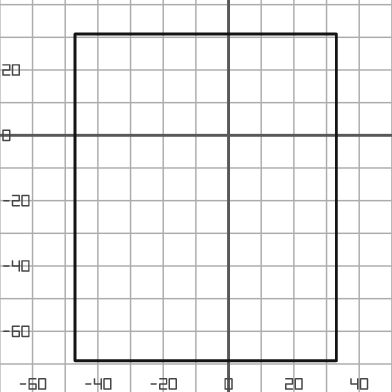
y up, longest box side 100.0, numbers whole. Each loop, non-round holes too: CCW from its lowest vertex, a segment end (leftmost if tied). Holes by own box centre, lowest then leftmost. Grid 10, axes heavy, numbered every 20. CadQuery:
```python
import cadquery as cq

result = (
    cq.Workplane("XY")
    .moveTo(-47.0, -69.0)
    .lineTo(33.0, -69.0)
    .lineTo(33.0, 31.0)
    .lineTo(-47.0, 31.0)
    .close()
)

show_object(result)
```